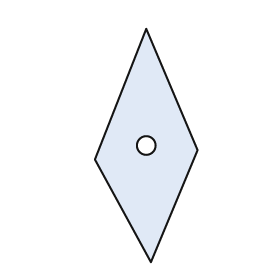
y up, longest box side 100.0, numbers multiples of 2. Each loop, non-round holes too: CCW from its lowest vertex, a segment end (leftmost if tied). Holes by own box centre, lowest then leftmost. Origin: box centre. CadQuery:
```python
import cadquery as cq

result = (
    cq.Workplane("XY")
    .moveTo(2.0, -50.0)
    .lineTo(22.0, -2.0)
    .lineTo(0.0, 50.0)
    .lineTo(-22.0, -6.0)
    .close()
    .moveTo(0.0, 0.0)
    .circle(4.0)
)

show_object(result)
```